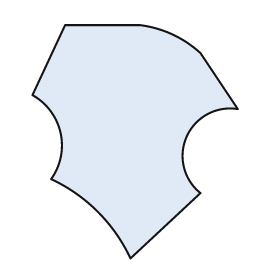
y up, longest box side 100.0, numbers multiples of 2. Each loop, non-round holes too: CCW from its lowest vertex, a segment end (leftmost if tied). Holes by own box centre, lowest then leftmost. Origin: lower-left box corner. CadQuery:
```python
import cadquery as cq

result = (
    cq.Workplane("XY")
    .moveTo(42.0, 0.0)
    .lineTo(72.0, 28.0)
    .threePointArc((66.0, 52.0), (88.0, 64.0))
    .lineTo(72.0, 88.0)
    .threePointArc((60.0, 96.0), (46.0, 100.0))
    .lineTo(14.0, 100.0)
    .lineTo(0.0, 70.0)
    .threePointArc((12.0, 54.0), (8.0, 34.0))
    .threePointArc((28.0, 20.0), (42.0, 0.0))
    .close()
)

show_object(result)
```